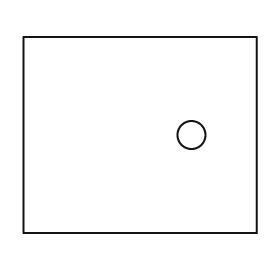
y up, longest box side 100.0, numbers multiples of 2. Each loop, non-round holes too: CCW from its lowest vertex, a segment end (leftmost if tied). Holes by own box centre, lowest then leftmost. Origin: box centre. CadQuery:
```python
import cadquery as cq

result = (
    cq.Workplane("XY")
    .moveTo(-50.0, -42.0)
    .lineTo(50.0, -42.0)
    .lineTo(50.0, 42.0)
    .lineTo(-50.0, 42.0)
    .close()
    .moveTo(22.0, 0.0)
    .circle(6.0)
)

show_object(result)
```